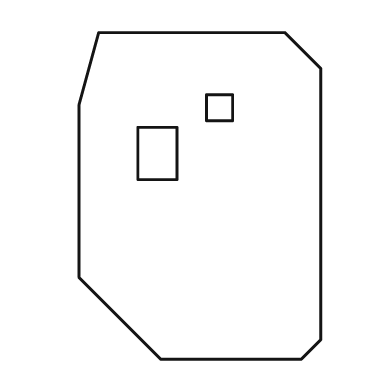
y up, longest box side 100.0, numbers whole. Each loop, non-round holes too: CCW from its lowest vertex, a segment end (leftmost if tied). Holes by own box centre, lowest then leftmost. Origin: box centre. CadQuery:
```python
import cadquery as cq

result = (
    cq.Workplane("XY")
    .moveTo(-12.0, -50.0)
    .lineTo(31.0, -50.0)
    .lineTo(37.0, -44.0)
    .lineTo(37.0, 39.0)
    .lineTo(26.0, 50.0)
    .lineTo(-31.0, 50.0)
    .lineTo(-37.0, 28.0)
    .lineTo(-37.0, -25.0)
    .close()
    .moveTo(-19.0, 5.0)
    .lineTo(-7.0, 5.0)
    .lineTo(-7.0, 21.0)
    .lineTo(-19.0, 21.0)
    .close()
    .moveTo(2.0, 23.0)
    .lineTo(10.0, 23.0)
    .lineTo(10.0, 31.0)
    .lineTo(2.0, 31.0)
    .close()
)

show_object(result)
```